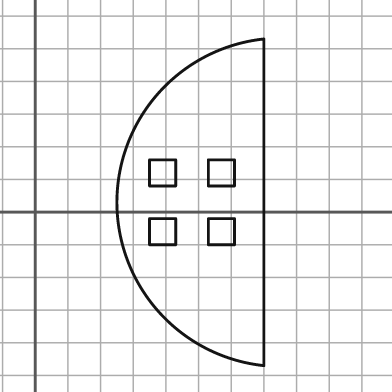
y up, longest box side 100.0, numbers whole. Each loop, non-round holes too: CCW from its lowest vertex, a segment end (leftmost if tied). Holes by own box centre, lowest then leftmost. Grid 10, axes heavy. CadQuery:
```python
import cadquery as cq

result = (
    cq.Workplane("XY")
    .moveTo(70.0, -47.0)
    .lineTo(70.0, 53.0)
    .threePointArc((25.0, 3.0), (70.0, -47.0))
    .close()
    .moveTo(35.0, -10.0)
    .lineTo(43.0, -10.0)
    .lineTo(43.0, -2.0)
    .lineTo(35.0, -2.0)
    .close()
    .moveTo(53.0, -10.0)
    .lineTo(61.0, -10.0)
    .lineTo(61.0, -2.0)
    .lineTo(53.0, -2.0)
    .close()
    .moveTo(35.0, 8.0)
    .lineTo(43.0, 8.0)
    .lineTo(43.0, 16.0)
    .lineTo(35.0, 16.0)
    .close()
    .moveTo(53.0, 8.0)
    .lineTo(61.0, 8.0)
    .lineTo(61.0, 16.0)
    .lineTo(53.0, 16.0)
    .close()
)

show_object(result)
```